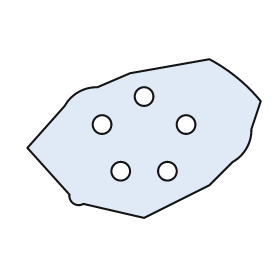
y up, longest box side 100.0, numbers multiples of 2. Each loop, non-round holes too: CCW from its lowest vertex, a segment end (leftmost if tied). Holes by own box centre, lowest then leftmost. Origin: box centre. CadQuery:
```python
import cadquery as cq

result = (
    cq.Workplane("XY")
    .moveTo(0.0, -34.0)
    .lineTo(28.0, -20.0)
    .lineTo(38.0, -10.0)
    .threePointArc((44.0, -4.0), (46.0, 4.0))
    .lineTo(50.0, 16.0)
    .threePointArc((40.0, 26.0), (28.0, 34.0))
    .lineTo(-6.0, 28.0)
    .lineTo(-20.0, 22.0)
    .threePointArc((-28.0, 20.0), (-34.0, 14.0))
    .lineTo(-50.0, -4.0)
    .lineTo(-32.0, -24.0)
    .threePointArc((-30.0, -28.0), (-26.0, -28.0))
    .close()
    .moveTo(-10.0, -14.0)
    .circle(4.0)
    .moveTo(10.0, -14.0)
    .circle(4.0)
    .moveTo(-18.0, 6.0)
    .circle(4.0)
    .moveTo(18.0, 6.0)
    .circle(4.0)
    .moveTo(0.0, 18.0)
    .circle(4.0)
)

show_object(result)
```